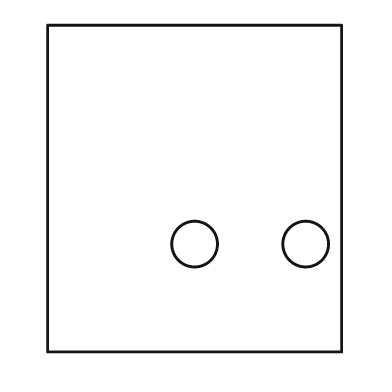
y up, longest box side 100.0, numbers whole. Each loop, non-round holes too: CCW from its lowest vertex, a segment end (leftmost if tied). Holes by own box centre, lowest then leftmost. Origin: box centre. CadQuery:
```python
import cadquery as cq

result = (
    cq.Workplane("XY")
    .moveTo(-45.0, -50.0)
    .lineTo(45.0, -50.0)
    .lineTo(45.0, 50.0)
    .lineTo(-45.0, 50.0)
    .close()
    .moveTo(0.0, -17.0)
    .circle(7.0)
    .moveTo(34.0, -17.0)
    .circle(7.0)
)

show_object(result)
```